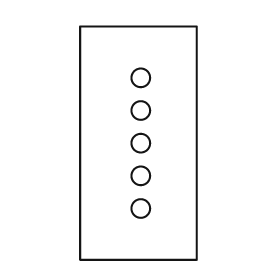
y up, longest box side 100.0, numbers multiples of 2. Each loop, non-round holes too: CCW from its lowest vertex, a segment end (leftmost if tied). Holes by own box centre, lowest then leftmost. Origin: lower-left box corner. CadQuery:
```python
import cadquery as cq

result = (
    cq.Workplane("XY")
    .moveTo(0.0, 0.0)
    .lineTo(50.0, 0.0)
    .lineTo(50.0, 100.0)
    .lineTo(0.0, 100.0)
    .close()
    .moveTo(26.0, 22.0)
    .circle(4.0)
    .moveTo(26.0, 36.0)
    .circle(4.0)
    .moveTo(26.0, 50.0)
    .circle(4.0)
    .moveTo(26.0, 64.0)
    .circle(4.0)
    .moveTo(26.0, 78.0)
    .circle(4.0)
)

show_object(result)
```